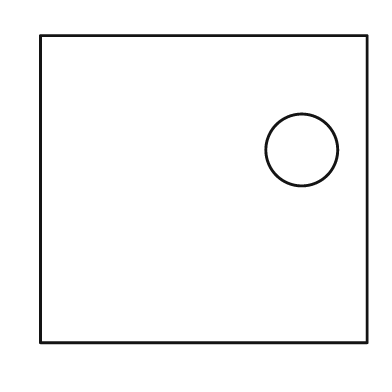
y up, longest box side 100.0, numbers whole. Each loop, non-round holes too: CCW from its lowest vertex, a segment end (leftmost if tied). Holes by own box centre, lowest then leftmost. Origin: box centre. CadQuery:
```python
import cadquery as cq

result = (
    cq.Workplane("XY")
    .moveTo(-50.0, -47.0)
    .lineTo(50.0, -47.0)
    .lineTo(50.0, 47.0)
    .lineTo(-50.0, 47.0)
    .close()
    .moveTo(30.0, 12.0)
    .circle(11.0)
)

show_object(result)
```